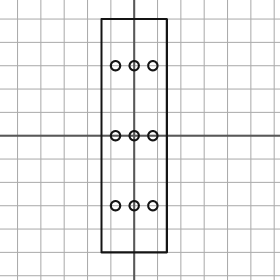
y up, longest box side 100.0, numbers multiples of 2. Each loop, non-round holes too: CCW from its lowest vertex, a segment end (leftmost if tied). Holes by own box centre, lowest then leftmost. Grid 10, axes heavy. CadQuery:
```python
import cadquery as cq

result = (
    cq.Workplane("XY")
    .moveTo(-14.0, -50.0)
    .lineTo(14.0, -50.0)
    .lineTo(14.0, 50.0)
    .lineTo(-14.0, 50.0)
    .close()
    .moveTo(-8.0, -30.0)
    .circle(2.0)
    .moveTo(0.0, -30.0)
    .circle(2.0)
    .moveTo(8.0, -30.0)
    .circle(2.0)
    .moveTo(-8.0, 0.0)
    .circle(2.0)
    .moveTo(0.0, 0.0)
    .circle(2.0)
    .moveTo(8.0, 0.0)
    .circle(2.0)
    .moveTo(-8.0, 30.0)
    .circle(2.0)
    .moveTo(0.0, 30.0)
    .circle(2.0)
    .moveTo(8.0, 30.0)
    .circle(2.0)
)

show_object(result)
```